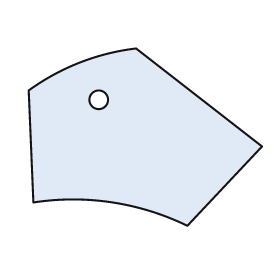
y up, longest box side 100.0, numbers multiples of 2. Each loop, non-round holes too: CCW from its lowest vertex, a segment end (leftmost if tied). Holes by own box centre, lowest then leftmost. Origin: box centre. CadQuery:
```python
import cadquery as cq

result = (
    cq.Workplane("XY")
    .moveTo(18.0, -38.0)
    .lineTo(50.0, -4.0)
    .lineTo(-4.0, 38.0)
    .threePointArc((-28.0, 32.0), (-50.0, 20.0))
    .lineTo(-48.0, -28.0)
    .threePointArc((-14.0, -28.0), (18.0, -38.0))
    .close()
    .moveTo(-20.0, 16.0)
    .circle(4.0)
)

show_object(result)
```